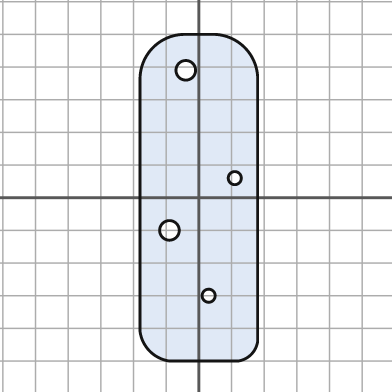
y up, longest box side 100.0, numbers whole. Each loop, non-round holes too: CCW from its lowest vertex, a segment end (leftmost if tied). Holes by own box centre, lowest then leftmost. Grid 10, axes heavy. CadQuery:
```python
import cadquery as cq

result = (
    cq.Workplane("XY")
    .moveTo(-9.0, -50.0)
    .lineTo(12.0, -50.0)
    .threePointArc((16.0, -48.0), (18.0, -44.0))
    .lineTo(18.0, 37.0)
    .threePointArc((14.0, 46.0), (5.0, 50.0))
    .lineTo(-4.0, 50.0)
    .threePointArc((-14.0, 46.0), (-18.0, 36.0))
    .lineTo(-18.0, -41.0)
    .threePointArc((-15.0, -47.0), (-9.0, -50.0))
    .close()
    .moveTo(3.0, -30.0)
    .circle(2.0)
    .moveTo(-9.0, -10.0)
    .circle(3.0)
    .moveTo(11.0, 6.0)
    .circle(2.0)
    .moveTo(-4.0, 39.0)
    .circle(3.0)
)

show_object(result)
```